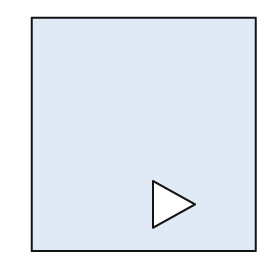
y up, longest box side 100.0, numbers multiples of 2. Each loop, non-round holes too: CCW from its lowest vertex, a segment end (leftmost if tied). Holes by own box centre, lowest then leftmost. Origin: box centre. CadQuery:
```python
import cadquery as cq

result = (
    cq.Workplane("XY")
    .moveTo(-48.0, -50.0)
    .lineTo(48.0, -50.0)
    .lineTo(48.0, 50.0)
    .lineTo(-48.0, 50.0)
    .close()
    .moveTo(4.0, -40.0)
    .lineTo(22.0, -30.0)
    .lineTo(4.0, -20.0)
    .close()
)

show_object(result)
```